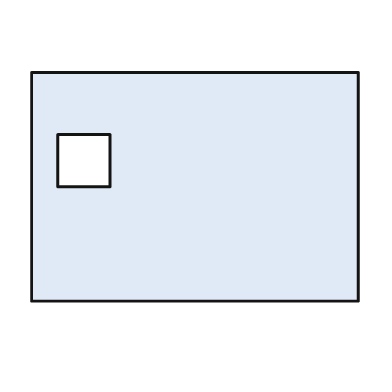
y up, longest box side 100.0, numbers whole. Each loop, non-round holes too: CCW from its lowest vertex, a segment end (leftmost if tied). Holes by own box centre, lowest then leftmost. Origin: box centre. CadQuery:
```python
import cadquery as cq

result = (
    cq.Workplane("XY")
    .moveTo(-50.0, -35.0)
    .lineTo(50.0, -35.0)
    .lineTo(50.0, 35.0)
    .lineTo(-50.0, 35.0)
    .close()
    .moveTo(-42.0, 0.0)
    .lineTo(-26.0, 0.0)
    .lineTo(-26.0, 16.0)
    .lineTo(-42.0, 16.0)
    .close()
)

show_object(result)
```